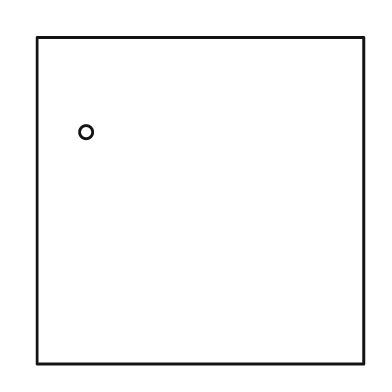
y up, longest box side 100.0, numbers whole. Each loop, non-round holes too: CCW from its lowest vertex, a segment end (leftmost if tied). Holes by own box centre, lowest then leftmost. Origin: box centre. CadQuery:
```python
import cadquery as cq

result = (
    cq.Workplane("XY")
    .moveTo(-50.0, -50.0)
    .lineTo(50.0, -50.0)
    .lineTo(50.0, 50.0)
    .lineTo(-50.0, 50.0)
    .close()
    .moveTo(-35.0, 21.0)
    .circle(2.0)
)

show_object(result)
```